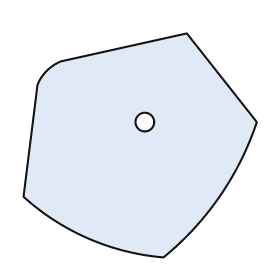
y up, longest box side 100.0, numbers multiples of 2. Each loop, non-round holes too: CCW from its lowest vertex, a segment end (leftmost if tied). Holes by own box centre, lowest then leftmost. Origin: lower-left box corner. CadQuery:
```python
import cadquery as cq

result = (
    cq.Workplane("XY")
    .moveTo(60.0, 0.0)
    .threePointArc((84.0, 26.0), (100.0, 58.0))
    .lineTo(70.0, 96.0)
    .lineTo(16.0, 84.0)
    .threePointArc((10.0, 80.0), (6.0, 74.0))
    .lineTo(0.0, 26.0)
    .threePointArc((28.0, 8.0), (60.0, 0.0))
    .close()
    .moveTo(52.0, 58.0)
    .circle(4.0)
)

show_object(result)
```